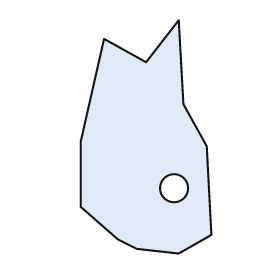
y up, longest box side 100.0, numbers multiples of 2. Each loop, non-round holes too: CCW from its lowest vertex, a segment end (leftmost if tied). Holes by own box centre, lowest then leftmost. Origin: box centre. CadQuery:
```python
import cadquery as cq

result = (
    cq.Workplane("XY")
    .moveTo(14.0, -50.0)
    .lineTo(28.0, -42.0)
    .lineTo(26.0, -4.0)
    .lineTo(16.0, 14.0)
    .lineTo(14.0, 50.0)
    .lineTo(0.0, 32.0)
    .lineTo(-18.0, 42.0)
    .lineTo(-28.0, -2.0)
    .lineTo(-28.0, -30.0)
    .lineTo(-12.0, -44.0)
    .lineTo(-4.0, -48.0)
    .close()
    .moveTo(12.0, -22.0)
    .circle(6.0)
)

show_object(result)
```